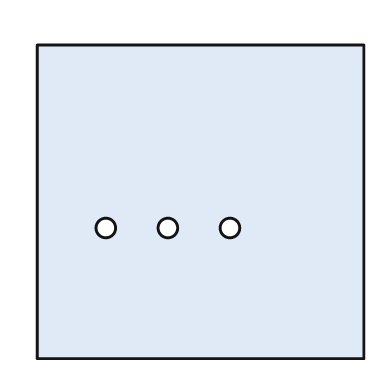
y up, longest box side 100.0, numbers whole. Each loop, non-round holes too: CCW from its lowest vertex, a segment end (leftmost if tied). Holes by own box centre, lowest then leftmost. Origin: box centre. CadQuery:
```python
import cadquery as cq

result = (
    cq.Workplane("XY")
    .moveTo(-50.0, -48.0)
    .lineTo(50.0, -48.0)
    .lineTo(50.0, 48.0)
    .lineTo(-50.0, 48.0)
    .close()
    .moveTo(-29.0, -8.0)
    .circle(3.0)
    .moveTo(-10.0, -8.0)
    .circle(3.0)
    .moveTo(9.0, -8.0)
    .circle(3.0)
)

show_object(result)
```